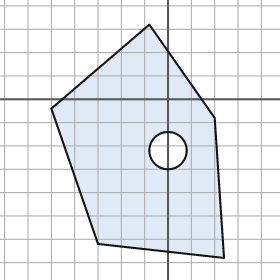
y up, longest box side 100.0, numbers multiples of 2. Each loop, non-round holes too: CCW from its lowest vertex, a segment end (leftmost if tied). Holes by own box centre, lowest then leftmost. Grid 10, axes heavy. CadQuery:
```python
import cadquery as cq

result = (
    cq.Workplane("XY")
    .moveTo(24.0, -68.0)
    .lineTo(20.0, -8.0)
    .lineTo(-8.0, 32.0)
    .lineTo(-50.0, -4.0)
    .lineTo(-30.0, -62.0)
    .close()
    .moveTo(0.0, -22.0)
    .circle(8.0)
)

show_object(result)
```